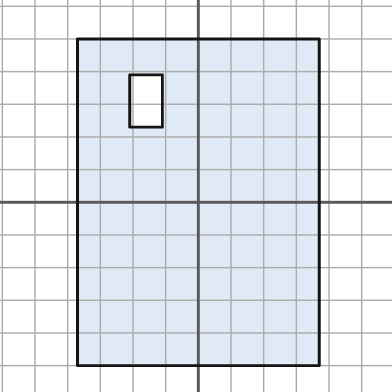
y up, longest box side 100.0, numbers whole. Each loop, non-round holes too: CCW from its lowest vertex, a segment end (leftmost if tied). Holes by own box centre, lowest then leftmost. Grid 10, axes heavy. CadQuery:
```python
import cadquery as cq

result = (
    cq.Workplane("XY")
    .moveTo(-37.0, -50.0)
    .lineTo(37.0, -50.0)
    .lineTo(37.0, 50.0)
    .lineTo(-37.0, 50.0)
    .close()
    .moveTo(-21.0, 23.0)
    .lineTo(-11.0, 23.0)
    .lineTo(-11.0, 39.0)
    .lineTo(-21.0, 39.0)
    .close()
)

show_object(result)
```